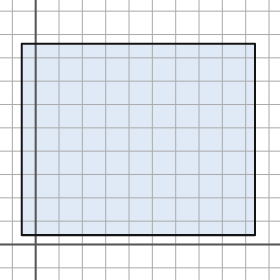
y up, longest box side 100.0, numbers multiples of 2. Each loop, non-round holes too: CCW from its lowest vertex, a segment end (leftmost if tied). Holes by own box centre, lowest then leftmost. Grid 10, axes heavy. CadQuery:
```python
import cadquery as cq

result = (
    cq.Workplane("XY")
    .moveTo(-6.0, 4.0)
    .lineTo(94.0, 4.0)
    .lineTo(94.0, 86.0)
    .lineTo(-6.0, 86.0)
    .close()
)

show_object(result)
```